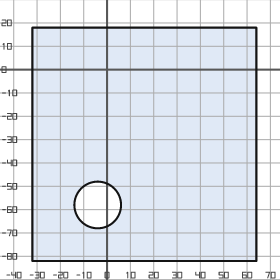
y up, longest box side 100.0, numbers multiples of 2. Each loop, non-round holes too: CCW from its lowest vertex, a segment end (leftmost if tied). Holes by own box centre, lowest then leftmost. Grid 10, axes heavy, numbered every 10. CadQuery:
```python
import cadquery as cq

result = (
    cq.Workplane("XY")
    .moveTo(-32.0, -82.0)
    .lineTo(64.0, -82.0)
    .lineTo(64.0, 18.0)
    .lineTo(-32.0, 18.0)
    .close()
    .moveTo(-4.0, -58.0)
    .circle(10.0)
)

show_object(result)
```